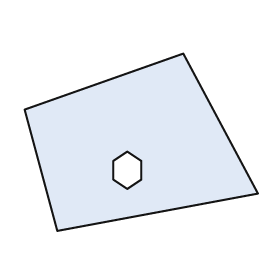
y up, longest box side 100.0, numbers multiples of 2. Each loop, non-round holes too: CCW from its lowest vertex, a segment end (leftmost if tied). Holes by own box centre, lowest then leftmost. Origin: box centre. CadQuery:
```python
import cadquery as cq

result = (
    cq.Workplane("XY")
    .moveTo(-36.0, -38.0)
    .lineTo(50.0, -22.0)
    .lineTo(18.0, 38.0)
    .lineTo(-50.0, 14.0)
    .close()
    .moveTo(-6.0, -20.0)
    .lineTo(0.0, -16.0)
    .lineTo(0.0, -8.0)
    .lineTo(-6.0, -4.0)
    .lineTo(-12.0, -8.0)
    .lineTo(-12.0, -16.0)
    .close()
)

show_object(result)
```